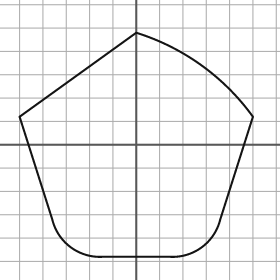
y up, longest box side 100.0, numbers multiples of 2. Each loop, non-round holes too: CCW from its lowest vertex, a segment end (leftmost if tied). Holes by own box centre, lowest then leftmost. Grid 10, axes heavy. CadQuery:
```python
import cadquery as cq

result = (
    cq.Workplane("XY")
    .moveTo(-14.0, -48.0)
    .lineTo(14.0, -48.0)
    .threePointArc((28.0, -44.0), (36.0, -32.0))
    .lineTo(50.0, 12.0)
    .threePointArc((28.0, 34.0), (0.0, 48.0))
    .lineTo(-50.0, 12.0)
    .lineTo(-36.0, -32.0)
    .threePointArc((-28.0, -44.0), (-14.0, -48.0))
    .close()
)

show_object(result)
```